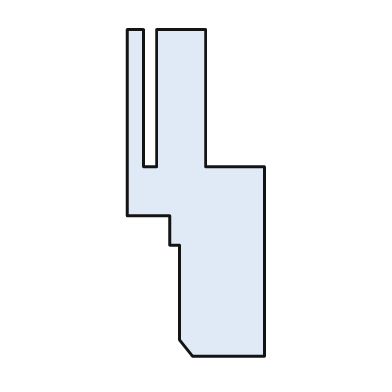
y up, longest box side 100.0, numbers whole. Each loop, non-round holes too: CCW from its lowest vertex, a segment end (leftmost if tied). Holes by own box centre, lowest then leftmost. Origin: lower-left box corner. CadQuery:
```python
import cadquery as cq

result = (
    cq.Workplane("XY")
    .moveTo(20.0, 0.0)
    .lineTo(42.0, 0.0)
    .lineTo(42.0, 58.0)
    .lineTo(24.0, 58.0)
    .lineTo(24.0, 100.0)
    .lineTo(9.0, 100.0)
    .lineTo(9.0, 58.0)
    .lineTo(5.0, 58.0)
    .lineTo(5.0, 100.0)
    .lineTo(0.0, 100.0)
    .lineTo(0.0, 43.0)
    .lineTo(13.0, 43.0)
    .lineTo(13.0, 34.0)
    .lineTo(16.0, 34.0)
    .lineTo(16.0, 5.0)
    .close()
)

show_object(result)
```